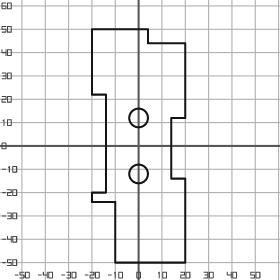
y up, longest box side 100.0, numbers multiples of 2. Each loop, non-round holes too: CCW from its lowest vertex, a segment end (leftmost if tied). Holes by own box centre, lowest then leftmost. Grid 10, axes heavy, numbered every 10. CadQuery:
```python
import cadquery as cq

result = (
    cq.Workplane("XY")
    .moveTo(-10.0, -50.0)
    .lineTo(20.0, -50.0)
    .lineTo(20.0, -14.0)
    .lineTo(14.0, -14.0)
    .lineTo(14.0, 12.0)
    .lineTo(20.0, 12.0)
    .lineTo(20.0, 44.0)
    .lineTo(4.0, 44.0)
    .lineTo(4.0, 50.0)
    .lineTo(-20.0, 50.0)
    .lineTo(-20.0, 22.0)
    .lineTo(-14.0, 22.0)
    .lineTo(-14.0, -20.0)
    .lineTo(-20.0, -20.0)
    .lineTo(-20.0, -24.0)
    .lineTo(-10.0, -24.0)
    .close()
    .moveTo(0.0, -12.0)
    .circle(4.0)
    .moveTo(0.0, 12.0)
    .circle(4.0)
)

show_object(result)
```